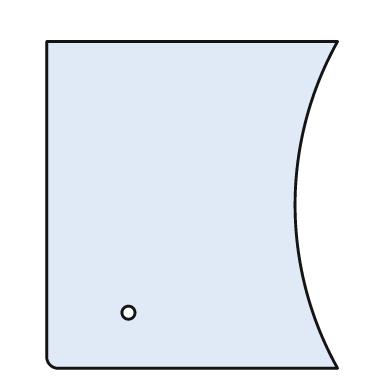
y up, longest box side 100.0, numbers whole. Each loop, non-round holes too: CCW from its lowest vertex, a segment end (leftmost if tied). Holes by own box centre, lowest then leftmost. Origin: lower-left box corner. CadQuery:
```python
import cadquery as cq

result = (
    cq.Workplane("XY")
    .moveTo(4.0, 0.0)
    .lineTo(89.0, 0.0)
    .threePointArc((76.0, 50.0), (89.0, 100.0))
    .lineTo(0.0, 100.0)
    .lineTo(0.0, 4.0)
    .threePointArc((1.0, 1.0), (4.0, 0.0))
    .close()
    .moveTo(25.0, 17.0)
    .circle(2.0)
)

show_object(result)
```